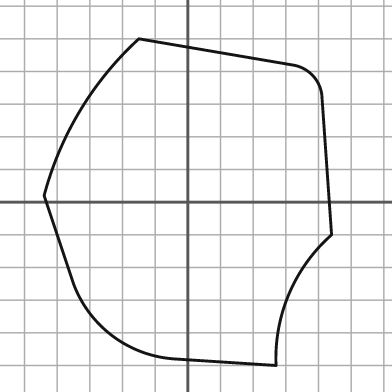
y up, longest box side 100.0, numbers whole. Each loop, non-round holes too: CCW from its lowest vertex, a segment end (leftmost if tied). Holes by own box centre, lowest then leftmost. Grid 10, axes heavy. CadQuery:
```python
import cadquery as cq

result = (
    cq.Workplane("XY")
    .moveTo(27.0, -50.0)
    .threePointArc((31.0, -28.0), (44.0, -10.0))
    .lineTo(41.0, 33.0)
    .threePointArc((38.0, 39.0), (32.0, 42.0))
    .lineTo(-15.0, 50.0)
    .threePointArc((-33.0, 28.0), (-44.0, 2.0))
    .lineTo(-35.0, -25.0)
    .threePointArc((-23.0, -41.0), (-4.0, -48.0))
    .close()
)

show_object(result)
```